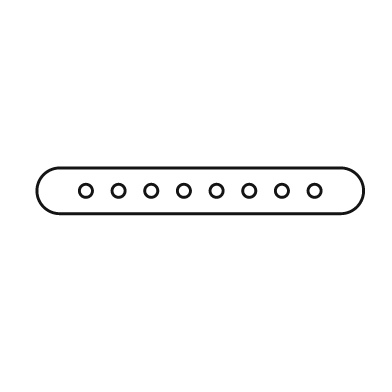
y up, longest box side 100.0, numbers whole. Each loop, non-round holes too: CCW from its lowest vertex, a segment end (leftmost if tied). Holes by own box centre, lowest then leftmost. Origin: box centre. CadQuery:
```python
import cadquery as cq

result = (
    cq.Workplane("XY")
    .moveTo(-43.0, -7.0)
    .lineTo(43.0, -7.0)
    .threePointArc((50.0, 0.0), (43.0, 7.0))
    .lineTo(-43.0, 7.0)
    .threePointArc((-50.0, 0.0), (-43.0, -7.0))
    .close()
    .moveTo(-35.0, 0.0)
    .circle(2.0)
    .moveTo(-25.0, 0.0)
    .circle(2.0)
    .moveTo(-15.0, 0.0)
    .circle(2.0)
    .moveTo(-5.0, 0.0)
    .circle(2.0)
    .moveTo(5.0, 0.0)
    .circle(2.0)
    .moveTo(15.0, 0.0)
    .circle(2.0)
    .moveTo(25.0, 0.0)
    .circle(2.0)
    .moveTo(35.0, 0.0)
    .circle(2.0)
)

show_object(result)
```